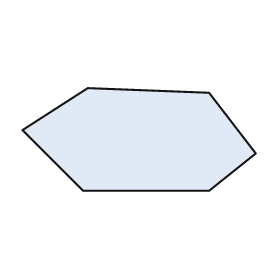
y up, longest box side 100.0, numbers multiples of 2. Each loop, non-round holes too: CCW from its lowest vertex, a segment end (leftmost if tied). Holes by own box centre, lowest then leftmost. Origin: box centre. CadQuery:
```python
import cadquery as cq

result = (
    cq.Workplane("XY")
    .moveTo(-24.0, -22.0)
    .lineTo(30.0, -22.0)
    .lineTo(50.0, -6.0)
    .lineTo(30.0, 20.0)
    .lineTo(-22.0, 22.0)
    .lineTo(-50.0, 4.0)
    .close()
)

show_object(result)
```